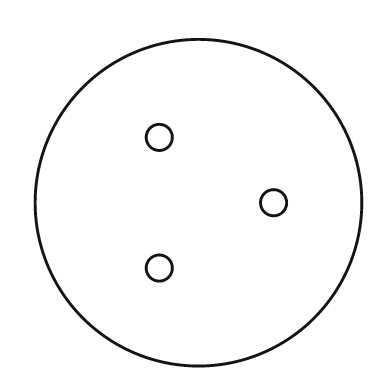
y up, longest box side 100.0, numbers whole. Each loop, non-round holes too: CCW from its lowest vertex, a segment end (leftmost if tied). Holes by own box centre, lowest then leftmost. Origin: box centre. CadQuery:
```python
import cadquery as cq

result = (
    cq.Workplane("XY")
    .moveTo(0.0, 0.0)
    .circle(50.0)
    .moveTo(-12.0, -20.0)
    .circle(4.0)
    .moveTo(23.0, 0.0)
    .circle(4.0)
    .moveTo(-12.0, 20.0)
    .circle(4.0)
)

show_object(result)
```